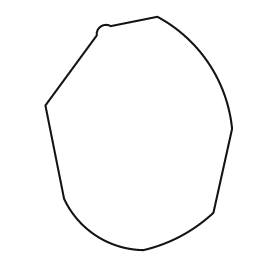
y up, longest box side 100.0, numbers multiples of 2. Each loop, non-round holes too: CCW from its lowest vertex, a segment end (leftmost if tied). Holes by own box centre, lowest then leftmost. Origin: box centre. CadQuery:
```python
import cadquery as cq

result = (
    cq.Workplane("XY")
    .moveTo(2.0, -50.0)
    .threePointArc((18.0, -44.0), (32.0, -34.0))
    .lineTo(40.0, 2.0)
    .threePointArc((30.0, 30.0), (8.0, 50.0))
    .lineTo(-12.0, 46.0)
    .threePointArc((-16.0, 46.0), (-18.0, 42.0))
    .lineTo(-40.0, 12.0)
    .lineTo(-32.0, -28.0)
    .threePointArc((-18.0, -44.0), (2.0, -50.0))
    .close()
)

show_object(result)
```